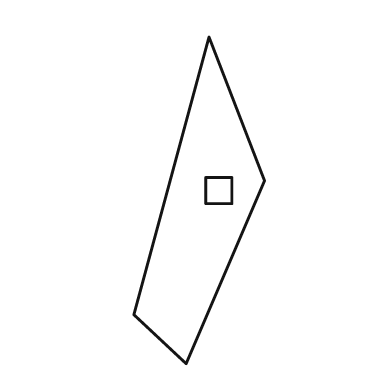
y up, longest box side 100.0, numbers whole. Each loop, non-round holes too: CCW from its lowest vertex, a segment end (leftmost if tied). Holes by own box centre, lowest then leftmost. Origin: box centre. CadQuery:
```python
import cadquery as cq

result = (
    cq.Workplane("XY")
    .moveTo(-4.0, -50.0)
    .lineTo(20.0, 6.0)
    .lineTo(3.0, 50.0)
    .lineTo(-20.0, -35.0)
    .close()
    .moveTo(2.0, -1.0)
    .lineTo(10.0, -1.0)
    .lineTo(10.0, 7.0)
    .lineTo(2.0, 7.0)
    .close()
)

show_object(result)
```